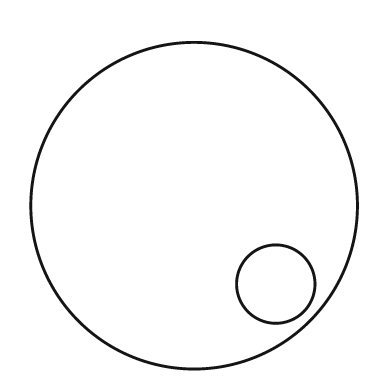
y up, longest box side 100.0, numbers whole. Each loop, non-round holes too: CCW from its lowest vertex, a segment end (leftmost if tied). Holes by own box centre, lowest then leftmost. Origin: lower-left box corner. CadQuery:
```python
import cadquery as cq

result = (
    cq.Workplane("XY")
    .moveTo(50.0, 50.0)
    .circle(50.0)
    .moveTo(75.0, 26.0)
    .circle(12.0)
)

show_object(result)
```